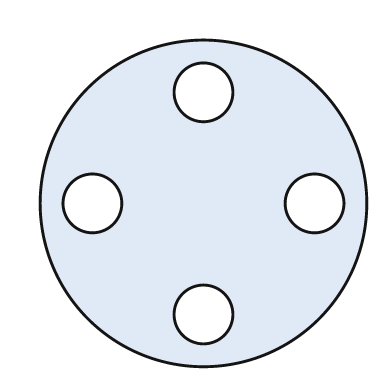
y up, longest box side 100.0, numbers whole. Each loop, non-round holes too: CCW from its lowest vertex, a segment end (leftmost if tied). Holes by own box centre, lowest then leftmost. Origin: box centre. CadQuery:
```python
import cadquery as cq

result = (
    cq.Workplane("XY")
    .moveTo(0.0, 0.0)
    .circle(50.0)
    .moveTo(0.0, -34.0)
    .circle(9.0)
    .moveTo(-34.0, 0.0)
    .circle(9.0)
    .moveTo(34.0, 0.0)
    .circle(9.0)
    .moveTo(0.0, 34.0)
    .circle(9.0)
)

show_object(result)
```